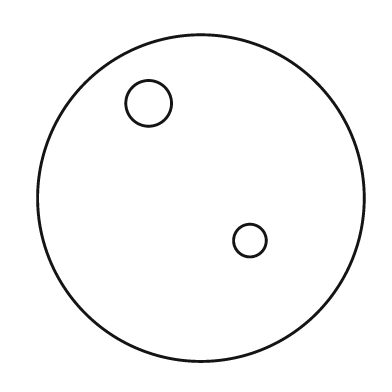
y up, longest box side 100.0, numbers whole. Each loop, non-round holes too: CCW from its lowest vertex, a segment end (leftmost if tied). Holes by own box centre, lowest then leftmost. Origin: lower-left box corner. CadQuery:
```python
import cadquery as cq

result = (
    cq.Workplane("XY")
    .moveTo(50.0, 50.0)
    .circle(50.0)
    .moveTo(65.0, 37.0)
    .circle(5.0)
    .moveTo(34.0, 79.0)
    .circle(7.0)
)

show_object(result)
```